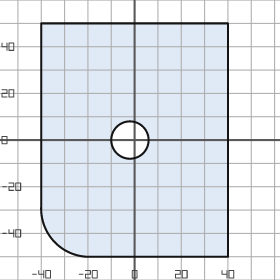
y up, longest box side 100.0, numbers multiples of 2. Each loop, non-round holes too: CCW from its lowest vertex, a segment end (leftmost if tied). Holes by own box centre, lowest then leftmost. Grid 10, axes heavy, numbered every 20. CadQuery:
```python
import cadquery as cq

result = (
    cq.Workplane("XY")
    .moveTo(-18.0, -50.0)
    .lineTo(40.0, -50.0)
    .lineTo(40.0, 50.0)
    .lineTo(-40.0, 50.0)
    .lineTo(-40.0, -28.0)
    .threePointArc((-34.0, -44.0), (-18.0, -50.0))
    .close()
    .moveTo(-2.0, 0.0)
    .circle(8.0)
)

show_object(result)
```